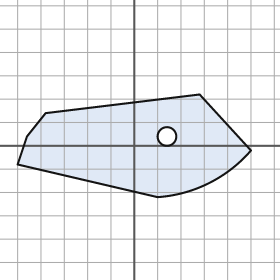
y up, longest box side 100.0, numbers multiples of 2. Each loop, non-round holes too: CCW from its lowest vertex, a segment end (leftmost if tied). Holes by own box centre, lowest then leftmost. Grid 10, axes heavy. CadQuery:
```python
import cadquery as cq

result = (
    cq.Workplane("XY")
    .moveTo(10.0, -22.0)
    .threePointArc((32.0, -16.0), (50.0, -2.0))
    .lineTo(28.0, 22.0)
    .lineTo(-38.0, 14.0)
    .lineTo(-46.0, 4.0)
    .lineTo(-50.0, -8.0)
    .close()
    .moveTo(14.0, 4.0)
    .circle(4.0)
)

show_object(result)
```